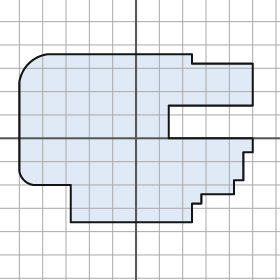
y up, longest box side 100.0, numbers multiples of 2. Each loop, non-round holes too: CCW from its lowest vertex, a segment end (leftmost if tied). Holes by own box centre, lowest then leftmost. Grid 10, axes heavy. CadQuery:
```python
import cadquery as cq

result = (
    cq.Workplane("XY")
    .moveTo(-28.0, -36.0)
    .lineTo(24.0, -36.0)
    .lineTo(24.0, -28.0)
    .lineTo(28.0, -28.0)
    .lineTo(28.0, -24.0)
    .lineTo(42.0, -24.0)
    .lineTo(42.0, -18.0)
    .lineTo(46.0, -18.0)
    .lineTo(46.0, -6.0)
    .lineTo(50.0, -6.0)
    .lineTo(50.0, 0.0)
    .lineTo(14.0, 0.0)
    .lineTo(14.0, 14.0)
    .lineTo(50.0, 14.0)
    .lineTo(50.0, 32.0)
    .lineTo(24.0, 32.0)
    .lineTo(24.0, 36.0)
    .lineTo(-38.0, 36.0)
    .threePointArc((-46.0, 32.0), (-50.0, 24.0))
    .lineTo(-50.0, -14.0)
    .threePointArc((-48.0, -18.0), (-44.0, -20.0))
    .lineTo(-28.0, -20.0)
    .close()
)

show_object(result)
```